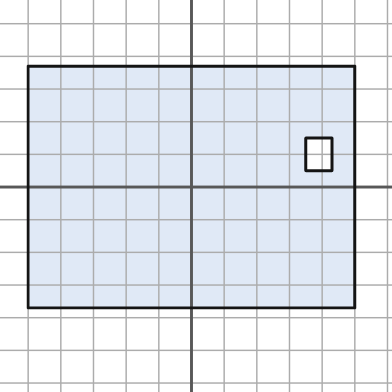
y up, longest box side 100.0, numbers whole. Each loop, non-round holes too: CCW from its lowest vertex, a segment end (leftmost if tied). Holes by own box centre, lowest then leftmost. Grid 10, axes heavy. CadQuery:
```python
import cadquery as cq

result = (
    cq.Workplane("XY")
    .moveTo(-50.0, -37.0)
    .lineTo(50.0, -37.0)
    .lineTo(50.0, 37.0)
    .lineTo(-50.0, 37.0)
    .close()
    .moveTo(35.0, 5.0)
    .lineTo(43.0, 5.0)
    .lineTo(43.0, 15.0)
    .lineTo(35.0, 15.0)
    .close()
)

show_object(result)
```